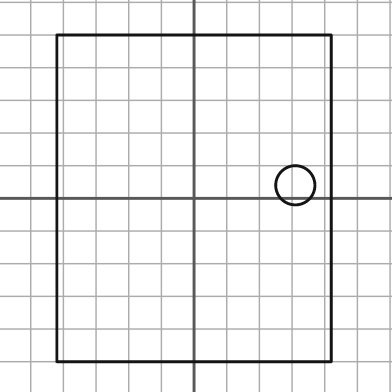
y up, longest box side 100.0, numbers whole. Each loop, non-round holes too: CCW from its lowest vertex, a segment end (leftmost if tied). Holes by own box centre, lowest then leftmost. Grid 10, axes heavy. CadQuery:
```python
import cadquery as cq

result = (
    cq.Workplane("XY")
    .moveTo(-42.0, -50.0)
    .lineTo(42.0, -50.0)
    .lineTo(42.0, 50.0)
    .lineTo(-42.0, 50.0)
    .close()
    .moveTo(31.0, 4.0)
    .circle(6.0)
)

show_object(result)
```